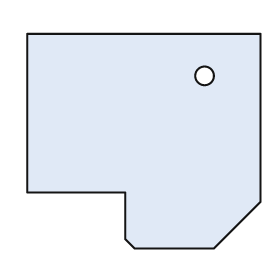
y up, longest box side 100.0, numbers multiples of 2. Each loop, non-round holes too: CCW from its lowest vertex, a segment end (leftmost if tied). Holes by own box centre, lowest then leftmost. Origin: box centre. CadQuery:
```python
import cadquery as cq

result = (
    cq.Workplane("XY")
    .moveTo(-4.0, -46.0)
    .lineTo(30.0, -46.0)
    .lineTo(50.0, -26.0)
    .lineTo(50.0, 46.0)
    .lineTo(-50.0, 46.0)
    .lineTo(-50.0, -22.0)
    .lineTo(-8.0, -22.0)
    .lineTo(-8.0, -42.0)
    .close()
    .moveTo(26.0, 28.0)
    .circle(4.0)
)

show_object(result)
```